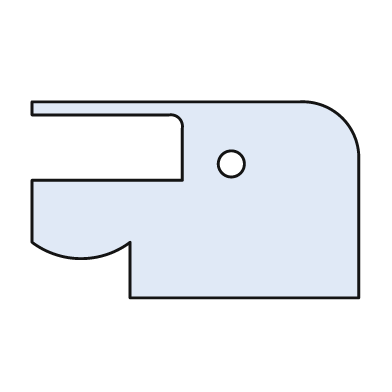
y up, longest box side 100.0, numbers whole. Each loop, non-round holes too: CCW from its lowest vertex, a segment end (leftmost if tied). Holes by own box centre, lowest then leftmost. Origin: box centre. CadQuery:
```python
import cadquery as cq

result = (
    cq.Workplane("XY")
    .moveTo(-20.0, -30.0)
    .lineTo(50.0, -30.0)
    .lineTo(50.0, 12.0)
    .threePointArc((45.0, 25.0), (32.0, 30.0))
    .lineTo(-50.0, 30.0)
    .lineTo(-50.0, 26.0)
    .lineTo(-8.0, 26.0)
    .threePointArc((-5.0, 25.0), (-4.0, 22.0))
    .lineTo(-4.0, 6.0)
    .lineTo(-50.0, 6.0)
    .lineTo(-50.0, -13.0)
    .threePointArc((-35.0, -18.0), (-20.0, -13.0))
    .close()
    .moveTo(11.0, 11.0)
    .circle(4.0)
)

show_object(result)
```